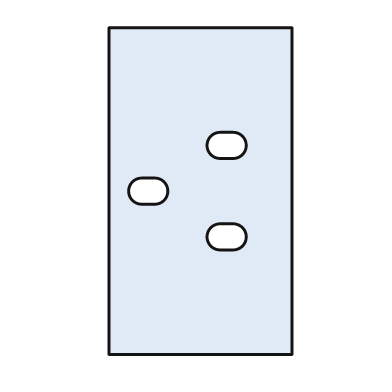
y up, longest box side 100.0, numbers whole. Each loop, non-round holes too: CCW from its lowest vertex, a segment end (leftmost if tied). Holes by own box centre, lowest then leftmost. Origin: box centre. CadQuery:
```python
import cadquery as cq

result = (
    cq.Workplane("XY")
    .moveTo(-28.0, -50.0)
    .lineTo(28.0, -50.0)
    .lineTo(28.0, 50.0)
    .lineTo(-28.0, 50.0)
    .close()
    .moveTo(6.0, -18.0)
    .lineTo(10.0, -18.0)
    .threePointArc((14.0, -14.0), (10.0, -10.0))
    .lineTo(6.0, -10.0)
    .threePointArc((2.0, -14.0), (6.0, -18.0))
    .close()
    .moveTo(-18.0, -4.0)
    .lineTo(-14.0, -4.0)
    .threePointArc((-10.0, 0.0), (-14.0, 4.0))
    .lineTo(-18.0, 4.0)
    .threePointArc((-22.0, 0.0), (-18.0, -4.0))
    .close()
    .moveTo(6.0, 10.0)
    .lineTo(10.0, 10.0)
    .threePointArc((14.0, 14.0), (10.0, 18.0))
    .lineTo(6.0, 18.0)
    .threePointArc((2.0, 14.0), (6.0, 10.0))
    .close()
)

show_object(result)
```